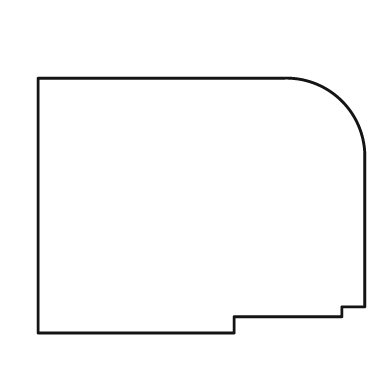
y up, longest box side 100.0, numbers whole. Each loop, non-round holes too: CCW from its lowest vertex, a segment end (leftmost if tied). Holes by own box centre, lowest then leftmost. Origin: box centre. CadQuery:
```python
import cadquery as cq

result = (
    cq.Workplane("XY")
    .moveTo(-50.0, -39.0)
    .lineTo(10.0, -39.0)
    .lineTo(10.0, -34.0)
    .lineTo(43.0, -34.0)
    .lineTo(43.0, -31.0)
    .lineTo(50.0, -31.0)
    .lineTo(50.0, 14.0)
    .threePointArc((43.0, 32.0), (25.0, 39.0))
    .lineTo(-50.0, 39.0)
    .close()
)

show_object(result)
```